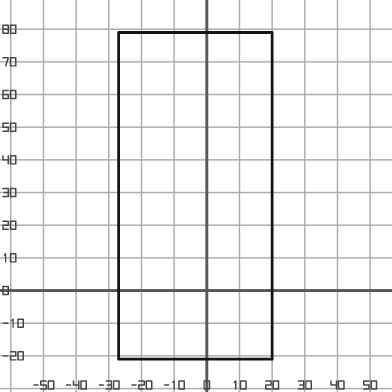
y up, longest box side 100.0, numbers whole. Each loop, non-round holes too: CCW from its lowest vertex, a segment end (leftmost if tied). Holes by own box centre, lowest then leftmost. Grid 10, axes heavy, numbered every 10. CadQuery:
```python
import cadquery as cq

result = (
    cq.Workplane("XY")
    .moveTo(-27.0, -21.0)
    .lineTo(20.0, -21.0)
    .lineTo(20.0, 79.0)
    .lineTo(-27.0, 79.0)
    .close()
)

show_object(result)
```